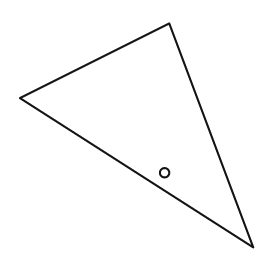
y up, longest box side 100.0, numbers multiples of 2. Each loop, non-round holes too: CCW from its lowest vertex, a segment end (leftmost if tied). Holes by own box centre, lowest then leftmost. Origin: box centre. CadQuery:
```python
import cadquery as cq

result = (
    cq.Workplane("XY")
    .moveTo(50.0, -48.0)
    .lineTo(14.0, 48.0)
    .lineTo(-50.0, 16.0)
    .close()
    .moveTo(12.0, -16.0)
    .circle(2.0)
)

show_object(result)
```